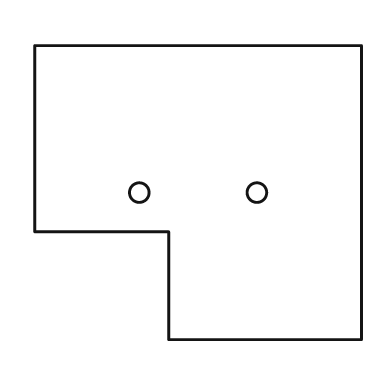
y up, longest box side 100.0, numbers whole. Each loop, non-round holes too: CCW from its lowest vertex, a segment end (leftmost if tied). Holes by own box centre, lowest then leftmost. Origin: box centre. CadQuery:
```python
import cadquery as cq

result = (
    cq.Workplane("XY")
    .moveTo(-9.0, -45.0)
    .lineTo(50.0, -45.0)
    .lineTo(50.0, 45.0)
    .lineTo(-50.0, 45.0)
    .lineTo(-50.0, -12.0)
    .lineTo(-9.0, -12.0)
    .close()
    .moveTo(-18.0, 0.0)
    .circle(3.0)
    .moveTo(18.0, 0.0)
    .circle(3.0)
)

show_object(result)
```